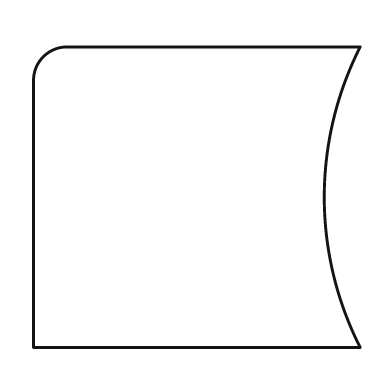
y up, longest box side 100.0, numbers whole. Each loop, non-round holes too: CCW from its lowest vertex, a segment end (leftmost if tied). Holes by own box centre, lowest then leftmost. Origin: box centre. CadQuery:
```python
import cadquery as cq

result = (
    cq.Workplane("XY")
    .moveTo(-50.0, -46.0)
    .lineTo(50.0, -46.0)
    .threePointArc((39.0, 0.0), (50.0, 46.0))
    .lineTo(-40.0, 46.0)
    .threePointArc((-47.0, 43.0), (-50.0, 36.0))
    .close()
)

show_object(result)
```